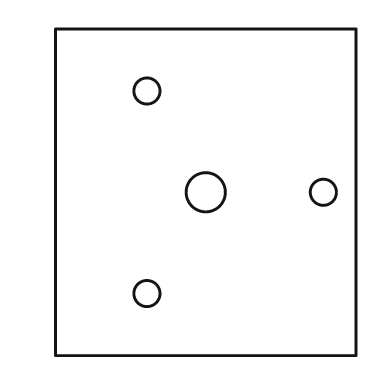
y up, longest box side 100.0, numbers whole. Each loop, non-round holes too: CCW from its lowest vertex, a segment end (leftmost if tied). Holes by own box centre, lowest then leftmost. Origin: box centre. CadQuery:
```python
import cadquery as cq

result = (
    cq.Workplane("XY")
    .moveTo(-46.0, -50.0)
    .lineTo(46.0, -50.0)
    .lineTo(46.0, 50.0)
    .lineTo(-46.0, 50.0)
    .close()
    .moveTo(-18.0, -31.0)
    .circle(4.0)
    .moveTo(0.0, 0.0)
    .circle(6.0)
    .moveTo(36.0, 0.0)
    .circle(4.0)
    .moveTo(-18.0, 31.0)
    .circle(4.0)
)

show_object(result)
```